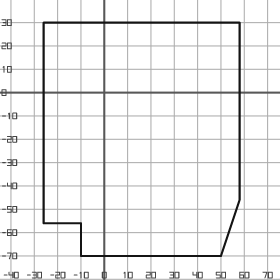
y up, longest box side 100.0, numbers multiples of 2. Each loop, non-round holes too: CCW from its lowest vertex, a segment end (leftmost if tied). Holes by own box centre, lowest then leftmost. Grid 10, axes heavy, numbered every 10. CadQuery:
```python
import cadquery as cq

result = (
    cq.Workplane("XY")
    .moveTo(-10.0, -70.0)
    .lineTo(50.0, -70.0)
    .lineTo(58.0, -46.0)
    .lineTo(58.0, 30.0)
    .lineTo(-26.0, 30.0)
    .lineTo(-26.0, -56.0)
    .lineTo(-10.0, -56.0)
    .close()
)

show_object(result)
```